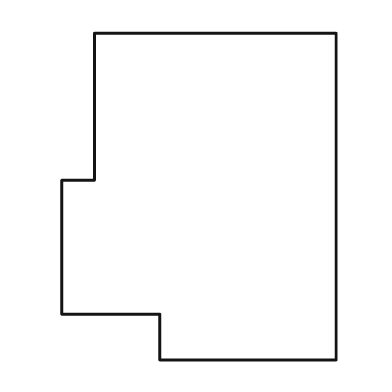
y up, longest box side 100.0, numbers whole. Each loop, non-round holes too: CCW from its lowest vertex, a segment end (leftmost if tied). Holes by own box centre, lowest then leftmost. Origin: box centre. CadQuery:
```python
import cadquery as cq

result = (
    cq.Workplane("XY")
    .moveTo(-12.0, -50.0)
    .lineTo(42.0, -50.0)
    .lineTo(42.0, 50.0)
    .lineTo(-32.0, 50.0)
    .lineTo(-32.0, 5.0)
    .lineTo(-42.0, 5.0)
    .lineTo(-42.0, -36.0)
    .lineTo(-12.0, -36.0)
    .close()
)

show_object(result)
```